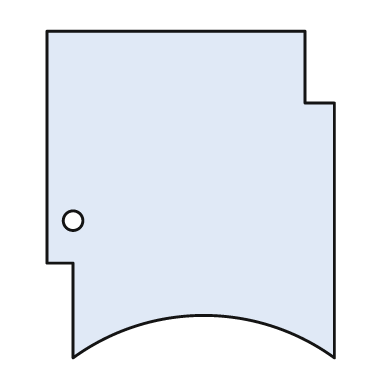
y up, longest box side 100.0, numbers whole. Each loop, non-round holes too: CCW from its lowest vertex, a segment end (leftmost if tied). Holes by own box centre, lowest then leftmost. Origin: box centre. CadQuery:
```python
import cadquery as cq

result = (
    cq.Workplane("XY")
    .moveTo(-36.0, -50.0)
    .threePointArc((4.0, -37.0), (44.0, -50.0))
    .lineTo(44.0, 28.0)
    .lineTo(35.0, 28.0)
    .lineTo(35.0, 50.0)
    .lineTo(-44.0, 50.0)
    .lineTo(-44.0, -21.0)
    .lineTo(-36.0, -21.0)
    .close()
    .moveTo(-36.0, -8.0)
    .circle(3.0)
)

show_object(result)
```